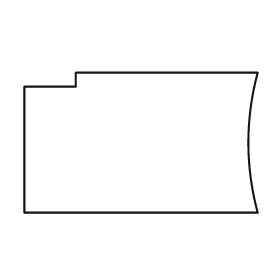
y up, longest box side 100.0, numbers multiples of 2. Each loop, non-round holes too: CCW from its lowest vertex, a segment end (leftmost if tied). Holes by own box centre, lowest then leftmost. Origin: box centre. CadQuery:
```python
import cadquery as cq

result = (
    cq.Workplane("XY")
    .moveTo(-50.0, -30.0)
    .lineTo(50.0, -30.0)
    .threePointArc((46.0, 0.0), (50.0, 30.0))
    .lineTo(-28.0, 30.0)
    .lineTo(-28.0, 24.0)
    .lineTo(-50.0, 24.0)
    .close()
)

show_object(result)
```